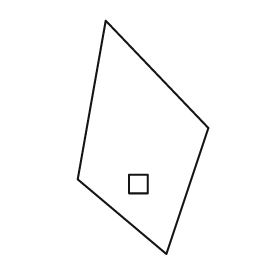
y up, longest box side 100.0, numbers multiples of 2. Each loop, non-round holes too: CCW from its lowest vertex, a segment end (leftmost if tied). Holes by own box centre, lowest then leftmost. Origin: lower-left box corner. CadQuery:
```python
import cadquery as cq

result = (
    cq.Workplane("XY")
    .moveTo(38.0, 0.0)
    .lineTo(56.0, 54.0)
    .lineTo(12.0, 100.0)
    .lineTo(0.0, 32.0)
    .close()
    .moveTo(22.0, 26.0)
    .lineTo(30.0, 26.0)
    .lineTo(30.0, 34.0)
    .lineTo(22.0, 34.0)
    .close()
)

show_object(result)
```